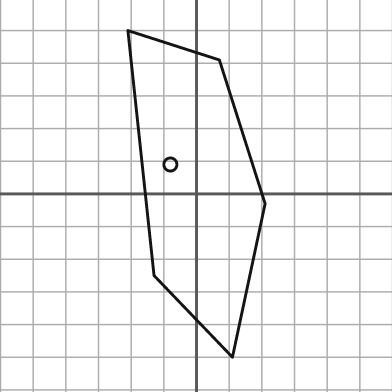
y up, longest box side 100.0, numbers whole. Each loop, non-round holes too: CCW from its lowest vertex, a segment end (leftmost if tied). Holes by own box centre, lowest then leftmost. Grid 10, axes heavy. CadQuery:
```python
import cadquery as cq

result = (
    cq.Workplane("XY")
    .moveTo(11.0, -50.0)
    .lineTo(21.0, -3.0)
    .lineTo(7.0, 41.0)
    .lineTo(-21.0, 50.0)
    .lineTo(-13.0, -25.0)
    .close()
    .moveTo(-8.0, 9.0)
    .circle(2.0)
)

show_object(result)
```